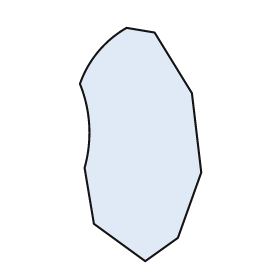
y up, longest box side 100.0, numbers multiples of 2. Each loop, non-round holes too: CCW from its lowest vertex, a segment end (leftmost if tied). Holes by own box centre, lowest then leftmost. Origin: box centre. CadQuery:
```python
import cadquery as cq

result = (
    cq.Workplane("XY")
    .moveTo(2.0, -50.0)
    .lineTo(16.0, -40.0)
    .lineTo(26.0, -12.0)
    .lineTo(22.0, 22.0)
    .lineTo(6.0, 48.0)
    .lineTo(-6.0, 50.0)
    .threePointArc((-18.0, 40.0), (-26.0, 26.0))
    .threePointArc((-22.0, 8.0), (-24.0, -10.0))
    .lineTo(-20.0, -34.0)
    .close()
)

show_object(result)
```